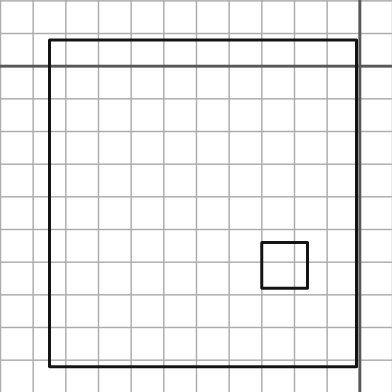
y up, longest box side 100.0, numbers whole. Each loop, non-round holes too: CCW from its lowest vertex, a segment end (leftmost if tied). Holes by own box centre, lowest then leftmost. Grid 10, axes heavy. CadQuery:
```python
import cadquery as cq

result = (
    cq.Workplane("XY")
    .moveTo(-95.0, -92.0)
    .lineTo(-1.0, -92.0)
    .lineTo(-1.0, 8.0)
    .lineTo(-95.0, 8.0)
    .close()
    .moveTo(-30.0, -68.0)
    .lineTo(-16.0, -68.0)
    .lineTo(-16.0, -54.0)
    .lineTo(-30.0, -54.0)
    .close()
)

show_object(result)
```